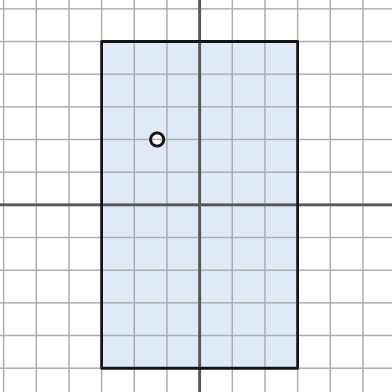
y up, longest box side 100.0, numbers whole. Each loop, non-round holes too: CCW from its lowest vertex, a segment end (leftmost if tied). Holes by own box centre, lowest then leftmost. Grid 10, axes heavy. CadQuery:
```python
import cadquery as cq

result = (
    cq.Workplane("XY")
    .moveTo(-30.0, -50.0)
    .lineTo(30.0, -50.0)
    .lineTo(30.0, 50.0)
    .lineTo(-30.0, 50.0)
    .close()
    .moveTo(-13.0, 20.0)
    .circle(2.0)
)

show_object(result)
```